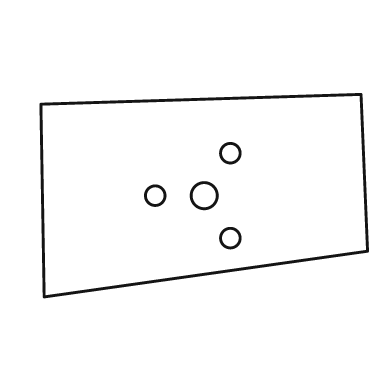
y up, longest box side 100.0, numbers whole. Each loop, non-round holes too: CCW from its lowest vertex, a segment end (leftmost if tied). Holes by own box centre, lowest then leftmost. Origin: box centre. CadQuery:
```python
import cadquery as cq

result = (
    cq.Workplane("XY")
    .moveTo(-49.0, -31.0)
    .lineTo(50.0, -17.0)
    .lineTo(48.0, 31.0)
    .lineTo(-50.0, 28.0)
    .close()
    .moveTo(8.0, -13.0)
    .circle(3.0)
    .moveTo(-15.0, 0.0)
    .circle(3.0)
    .moveTo(0.0, 0.0)
    .circle(4.0)
    .moveTo(8.0, 13.0)
    .circle(3.0)
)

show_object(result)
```